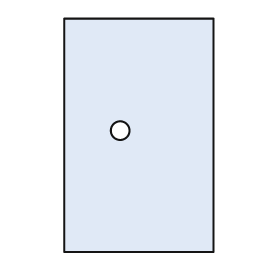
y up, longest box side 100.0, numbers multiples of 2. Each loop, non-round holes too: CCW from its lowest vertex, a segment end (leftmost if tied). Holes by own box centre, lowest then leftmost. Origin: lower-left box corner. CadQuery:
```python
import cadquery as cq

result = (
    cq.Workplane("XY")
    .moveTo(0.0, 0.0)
    .lineTo(64.0, 0.0)
    .lineTo(64.0, 100.0)
    .lineTo(0.0, 100.0)
    .close()
    .moveTo(24.0, 52.0)
    .circle(4.0)
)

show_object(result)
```